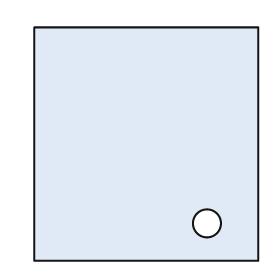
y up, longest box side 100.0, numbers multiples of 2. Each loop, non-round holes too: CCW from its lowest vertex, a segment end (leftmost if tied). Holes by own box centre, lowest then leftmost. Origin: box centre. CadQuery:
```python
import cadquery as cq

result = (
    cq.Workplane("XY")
    .moveTo(-48.0, -50.0)
    .lineTo(48.0, -50.0)
    .lineTo(48.0, 50.0)
    .lineTo(-48.0, 50.0)
    .close()
    .moveTo(26.0, -34.0)
    .circle(6.0)
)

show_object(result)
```